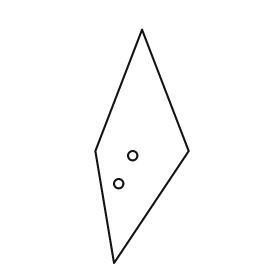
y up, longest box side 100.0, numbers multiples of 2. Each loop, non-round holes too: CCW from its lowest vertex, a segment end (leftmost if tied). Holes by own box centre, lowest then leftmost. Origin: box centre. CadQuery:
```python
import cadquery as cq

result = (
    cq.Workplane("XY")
    .moveTo(-12.0, -50.0)
    .lineTo(20.0, -2.0)
    .lineTo(0.0, 50.0)
    .lineTo(-20.0, -2.0)
    .close()
    .moveTo(-10.0, -16.0)
    .circle(2.0)
    .moveTo(-4.0, -4.0)
    .circle(2.0)
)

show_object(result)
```